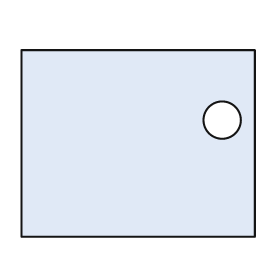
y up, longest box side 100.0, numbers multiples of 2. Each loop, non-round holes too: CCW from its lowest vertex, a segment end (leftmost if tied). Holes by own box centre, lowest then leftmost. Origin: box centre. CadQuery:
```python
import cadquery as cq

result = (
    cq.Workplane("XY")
    .moveTo(-50.0, -40.0)
    .lineTo(50.0, -40.0)
    .lineTo(50.0, 40.0)
    .lineTo(-50.0, 40.0)
    .close()
    .moveTo(36.0, 10.0)
    .circle(8.0)
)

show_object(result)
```